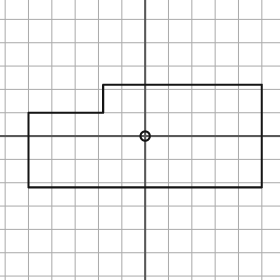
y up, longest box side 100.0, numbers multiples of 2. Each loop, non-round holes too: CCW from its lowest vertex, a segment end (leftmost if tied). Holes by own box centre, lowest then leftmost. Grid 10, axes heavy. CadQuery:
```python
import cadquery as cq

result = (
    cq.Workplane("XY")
    .moveTo(-50.0, -22.0)
    .lineTo(50.0, -22.0)
    .lineTo(50.0, 22.0)
    .lineTo(-18.0, 22.0)
    .lineTo(-18.0, 10.0)
    .lineTo(-50.0, 10.0)
    .close()
    .moveTo(0.0, 0.0)
    .circle(2.0)
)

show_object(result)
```